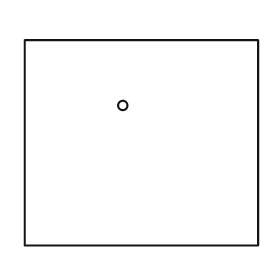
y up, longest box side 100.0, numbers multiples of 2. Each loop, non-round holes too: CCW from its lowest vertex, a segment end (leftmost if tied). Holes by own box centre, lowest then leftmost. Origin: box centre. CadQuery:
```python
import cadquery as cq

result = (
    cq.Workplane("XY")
    .moveTo(-50.0, -44.0)
    .lineTo(50.0, -44.0)
    .lineTo(50.0, 44.0)
    .lineTo(-50.0, 44.0)
    .close()
    .moveTo(-8.0, 16.0)
    .circle(2.0)
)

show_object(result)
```